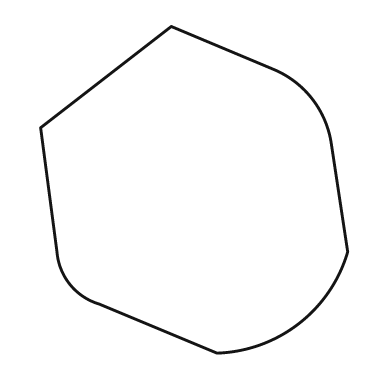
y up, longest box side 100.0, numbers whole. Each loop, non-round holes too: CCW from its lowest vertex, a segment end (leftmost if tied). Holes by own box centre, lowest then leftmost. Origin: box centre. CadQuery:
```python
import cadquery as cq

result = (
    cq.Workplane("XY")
    .moveTo(7.0, -50.0)
    .threePointArc((32.0, -41.0), (47.0, -19.0))
    .lineTo(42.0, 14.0)
    .threePointArc((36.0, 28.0), (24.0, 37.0))
    .lineTo(-7.0, 50.0)
    .lineTo(-47.0, 19.0)
    .lineTo(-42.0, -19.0)
    .threePointArc((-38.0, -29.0), (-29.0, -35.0))
    .close()
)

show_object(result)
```